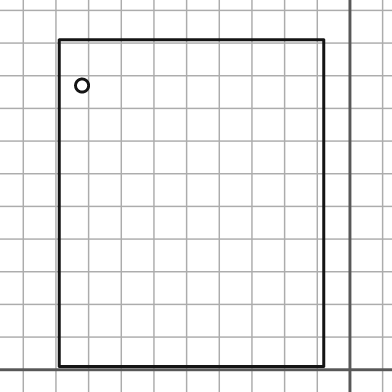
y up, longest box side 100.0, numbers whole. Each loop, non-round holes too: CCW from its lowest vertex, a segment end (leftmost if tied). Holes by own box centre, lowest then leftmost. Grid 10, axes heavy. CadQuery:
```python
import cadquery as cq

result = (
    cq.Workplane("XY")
    .moveTo(-89.0, 1.0)
    .lineTo(-8.0, 1.0)
    .lineTo(-8.0, 101.0)
    .lineTo(-89.0, 101.0)
    .close()
    .moveTo(-82.0, 87.0)
    .circle(2.0)
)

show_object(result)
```